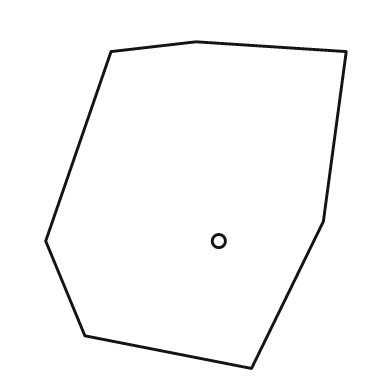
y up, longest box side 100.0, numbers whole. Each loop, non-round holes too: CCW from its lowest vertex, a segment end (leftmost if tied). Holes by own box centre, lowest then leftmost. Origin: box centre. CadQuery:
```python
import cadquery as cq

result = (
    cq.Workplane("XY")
    .moveTo(17.0, -50.0)
    .lineTo(39.0, -5.0)
    .lineTo(46.0, 47.0)
    .lineTo(0.0, 50.0)
    .lineTo(-26.0, 47.0)
    .lineTo(-46.0, -11.0)
    .lineTo(-34.0, -40.0)
    .close()
    .moveTo(7.0, -11.0)
    .circle(2.0)
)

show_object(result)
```